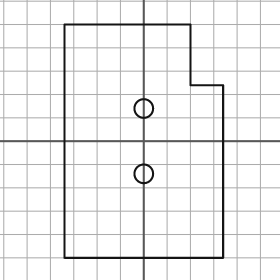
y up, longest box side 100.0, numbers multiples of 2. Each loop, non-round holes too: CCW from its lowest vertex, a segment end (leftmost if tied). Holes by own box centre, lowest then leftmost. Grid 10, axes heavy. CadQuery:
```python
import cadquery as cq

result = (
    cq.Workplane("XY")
    .moveTo(-34.0, -50.0)
    .lineTo(34.0, -50.0)
    .lineTo(34.0, 24.0)
    .lineTo(20.0, 24.0)
    .lineTo(20.0, 50.0)
    .lineTo(-34.0, 50.0)
    .close()
    .moveTo(0.0, -14.0)
    .circle(4.0)
    .moveTo(0.0, 14.0)
    .circle(4.0)
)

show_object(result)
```